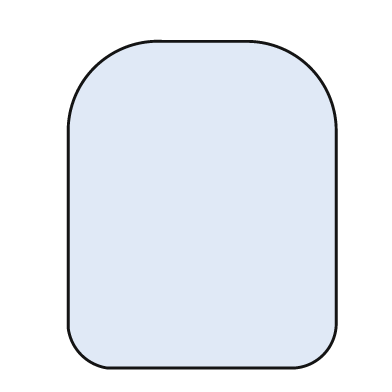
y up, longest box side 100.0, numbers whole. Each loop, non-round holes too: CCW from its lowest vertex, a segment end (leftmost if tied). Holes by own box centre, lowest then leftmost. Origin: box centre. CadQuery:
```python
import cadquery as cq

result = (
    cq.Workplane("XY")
    .moveTo(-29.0, -50.0)
    .lineTo(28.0, -50.0)
    .threePointArc((37.0, -46.0), (41.0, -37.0))
    .lineTo(41.0, 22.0)
    .threePointArc((33.0, 42.0), (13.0, 50.0))
    .lineTo(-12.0, 50.0)
    .threePointArc((-33.0, 42.0), (-41.0, 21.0))
    .lineTo(-41.0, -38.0)
    .threePointArc((-37.0, -46.0), (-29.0, -50.0))
    .close()
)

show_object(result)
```